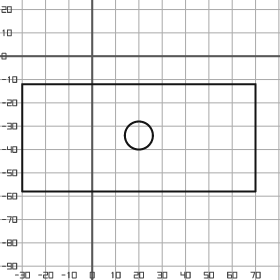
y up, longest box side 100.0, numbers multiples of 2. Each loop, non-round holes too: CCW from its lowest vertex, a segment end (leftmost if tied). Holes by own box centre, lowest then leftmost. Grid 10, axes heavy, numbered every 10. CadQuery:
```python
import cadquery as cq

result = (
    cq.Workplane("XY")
    .moveTo(-30.0, -58.0)
    .lineTo(70.0, -58.0)
    .lineTo(70.0, -12.0)
    .lineTo(-30.0, -12.0)
    .close()
    .moveTo(20.0, -34.0)
    .circle(6.0)
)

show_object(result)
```